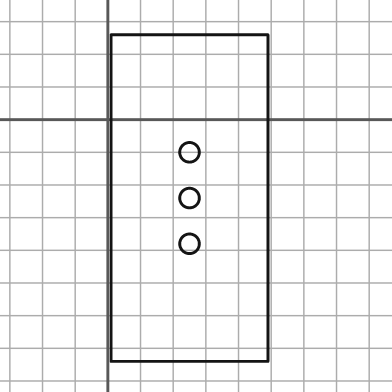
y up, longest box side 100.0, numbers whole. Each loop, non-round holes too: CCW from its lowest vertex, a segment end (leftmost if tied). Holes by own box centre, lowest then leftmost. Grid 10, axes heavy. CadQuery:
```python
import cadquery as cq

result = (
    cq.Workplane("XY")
    .moveTo(1.0, -74.0)
    .lineTo(49.0, -74.0)
    .lineTo(49.0, 26.0)
    .lineTo(1.0, 26.0)
    .close()
    .moveTo(25.0, -38.0)
    .circle(3.0)
    .moveTo(25.0, -24.0)
    .circle(3.0)
    .moveTo(25.0, -10.0)
    .circle(3.0)
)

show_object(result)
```